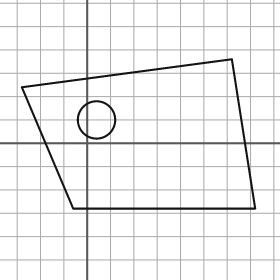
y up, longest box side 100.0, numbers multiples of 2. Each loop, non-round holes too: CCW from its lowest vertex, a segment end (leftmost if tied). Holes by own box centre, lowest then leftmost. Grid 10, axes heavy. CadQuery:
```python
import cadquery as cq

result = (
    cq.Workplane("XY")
    .moveTo(-6.0, -28.0)
    .lineTo(72.0, -28.0)
    .lineTo(62.0, 36.0)
    .lineTo(-28.0, 24.0)
    .close()
    .moveTo(4.0, 10.0)
    .circle(8.0)
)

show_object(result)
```